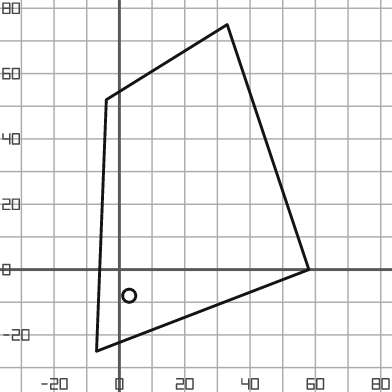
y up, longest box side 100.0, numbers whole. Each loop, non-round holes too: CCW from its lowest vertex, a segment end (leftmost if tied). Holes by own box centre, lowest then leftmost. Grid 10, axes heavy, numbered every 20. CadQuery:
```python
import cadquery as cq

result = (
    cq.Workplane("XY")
    .moveTo(-7.0, -25.0)
    .lineTo(58.0, 0.0)
    .lineTo(33.0, 75.0)
    .lineTo(-4.0, 52.0)
    .close()
    .moveTo(3.0, -8.0)
    .circle(2.0)
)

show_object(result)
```